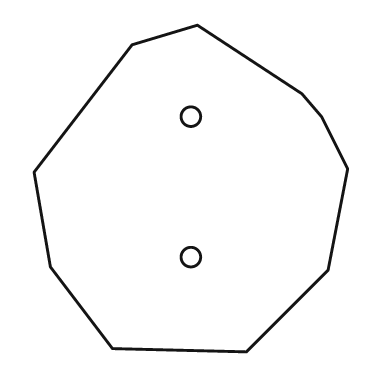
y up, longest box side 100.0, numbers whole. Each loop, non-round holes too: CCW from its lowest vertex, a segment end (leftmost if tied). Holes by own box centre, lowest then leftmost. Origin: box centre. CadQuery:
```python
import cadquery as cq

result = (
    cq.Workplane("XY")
    .moveTo(17.0, -50.0)
    .lineTo(42.0, -25.0)
    .lineTo(48.0, 6.0)
    .lineTo(40.0, 22.0)
    .lineTo(34.0, 29.0)
    .lineTo(2.0, 50.0)
    .lineTo(-18.0, 44.0)
    .lineTo(-48.0, 5.0)
    .lineTo(-43.0, -24.0)
    .lineTo(-24.0, -49.0)
    .close()
    .moveTo(0.0, -21.0)
    .circle(3.0)
    .moveTo(0.0, 22.0)
    .circle(3.0)
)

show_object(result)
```